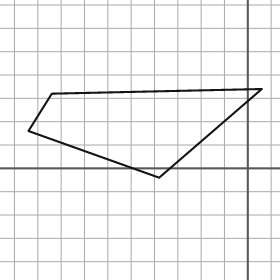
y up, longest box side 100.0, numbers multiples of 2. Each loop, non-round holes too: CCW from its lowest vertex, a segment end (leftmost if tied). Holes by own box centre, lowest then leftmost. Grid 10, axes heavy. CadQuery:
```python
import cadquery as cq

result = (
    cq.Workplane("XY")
    .moveTo(-38.0, -4.0)
    .lineTo(6.0, 34.0)
    .lineTo(-84.0, 32.0)
    .lineTo(-94.0, 16.0)
    .close()
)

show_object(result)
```